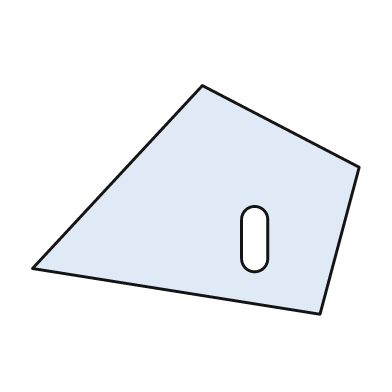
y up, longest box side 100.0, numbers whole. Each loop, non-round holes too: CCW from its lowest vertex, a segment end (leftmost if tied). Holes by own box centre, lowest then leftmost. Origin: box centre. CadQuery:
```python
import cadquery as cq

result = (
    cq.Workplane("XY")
    .moveTo(38.0, -35.0)
    .lineTo(50.0, 10.0)
    .lineTo(2.0, 35.0)
    .lineTo(-50.0, -21.0)
    .close()
    .moveTo(14.0, -18.0)
    .threePointArc((18.0, -22.0), (22.0, -18.0))
    .lineTo(22.0, -6.0)
    .threePointArc((18.0, -2.0), (14.0, -6.0))
    .close()
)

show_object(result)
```